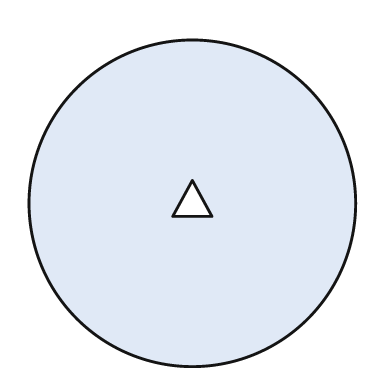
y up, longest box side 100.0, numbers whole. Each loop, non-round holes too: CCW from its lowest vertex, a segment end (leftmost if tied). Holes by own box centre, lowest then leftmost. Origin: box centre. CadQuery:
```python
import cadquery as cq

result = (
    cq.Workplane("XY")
    .moveTo(0.0, 0.0)
    .circle(50.0)
    .moveTo(-6.0, -4.0)
    .lineTo(6.0, -4.0)
    .lineTo(0.0, 7.0)
    .close()
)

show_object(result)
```